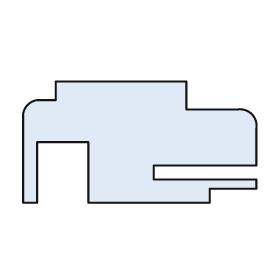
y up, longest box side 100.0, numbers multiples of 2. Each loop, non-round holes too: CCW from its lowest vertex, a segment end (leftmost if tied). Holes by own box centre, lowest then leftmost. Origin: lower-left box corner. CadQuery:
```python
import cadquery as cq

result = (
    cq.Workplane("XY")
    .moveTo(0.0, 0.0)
    .lineTo(6.0, 0.0)
    .lineTo(6.0, 26.0)
    .lineTo(28.0, 26.0)
    .lineTo(28.0, 0.0)
    .lineTo(80.0, 0.0)
    .lineTo(80.0, 6.0)
    .lineTo(100.0, 6.0)
    .lineTo(100.0, 10.0)
    .lineTo(56.0, 10.0)
    .lineTo(56.0, 16.0)
    .lineTo(100.0, 16.0)
    .lineTo(100.0, 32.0)
    .threePointArc((98.0, 38.0), (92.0, 40.0))
    .lineTo(70.0, 40.0)
    .lineTo(70.0, 52.0)
    .lineTo(14.0, 52.0)
    .lineTo(14.0, 44.0)
    .lineTo(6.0, 44.0)
    .threePointArc((2.0, 42.0), (0.0, 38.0))
    .close()
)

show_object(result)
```